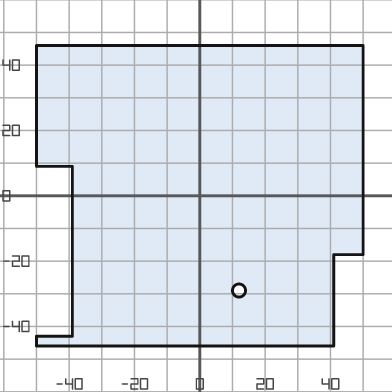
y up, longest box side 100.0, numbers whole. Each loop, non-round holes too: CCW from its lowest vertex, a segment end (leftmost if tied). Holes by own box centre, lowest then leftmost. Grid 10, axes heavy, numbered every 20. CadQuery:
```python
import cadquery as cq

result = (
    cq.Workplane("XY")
    .moveTo(-50.0, -46.0)
    .lineTo(41.0, -46.0)
    .lineTo(41.0, -18.0)
    .lineTo(50.0, -18.0)
    .lineTo(50.0, 46.0)
    .lineTo(-50.0, 46.0)
    .lineTo(-50.0, 9.0)
    .lineTo(-39.0, 9.0)
    .lineTo(-39.0, -43.0)
    .lineTo(-50.0, -43.0)
    .close()
    .moveTo(12.0, -29.0)
    .circle(2.0)
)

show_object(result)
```